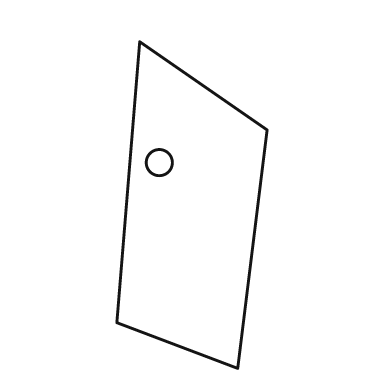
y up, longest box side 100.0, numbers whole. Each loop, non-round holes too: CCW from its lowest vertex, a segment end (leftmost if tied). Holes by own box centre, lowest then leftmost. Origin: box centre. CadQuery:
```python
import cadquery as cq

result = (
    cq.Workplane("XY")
    .moveTo(14.0, -50.0)
    .lineTo(23.0, 23.0)
    .lineTo(-16.0, 50.0)
    .lineTo(-23.0, -36.0)
    .close()
    .moveTo(-10.0, 13.0)
    .circle(4.0)
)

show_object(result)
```